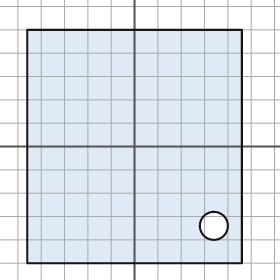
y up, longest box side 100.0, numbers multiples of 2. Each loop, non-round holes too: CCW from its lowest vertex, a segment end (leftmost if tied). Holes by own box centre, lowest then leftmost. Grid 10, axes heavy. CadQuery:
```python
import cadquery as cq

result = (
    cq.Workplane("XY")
    .moveTo(-46.0, -50.0)
    .lineTo(46.0, -50.0)
    .lineTo(46.0, 50.0)
    .lineTo(-46.0, 50.0)
    .close()
    .moveTo(34.0, -34.0)
    .circle(6.0)
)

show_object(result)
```